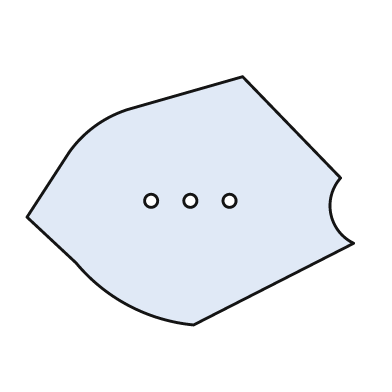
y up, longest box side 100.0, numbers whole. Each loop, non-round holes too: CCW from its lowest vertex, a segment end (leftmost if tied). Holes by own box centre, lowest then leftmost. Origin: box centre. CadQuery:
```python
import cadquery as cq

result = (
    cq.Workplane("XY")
    .moveTo(1.0, -38.0)
    .lineTo(50.0, -13.0)
    .threePointArc((43.0, -4.0), (46.0, 7.0))
    .lineTo(16.0, 38.0)
    .lineTo(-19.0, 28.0)
    .threePointArc((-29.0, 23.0), (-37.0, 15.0))
    .lineTo(-50.0, -5.0)
    .lineTo(-35.0, -19.0)
    .threePointArc((-19.0, -32.0), (1.0, -38.0))
    .close()
    .moveTo(-12.0, 0.0)
    .circle(2.0)
    .moveTo(0.0, 0.0)
    .circle(2.0)
    .moveTo(12.0, 0.0)
    .circle(2.0)
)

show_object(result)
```